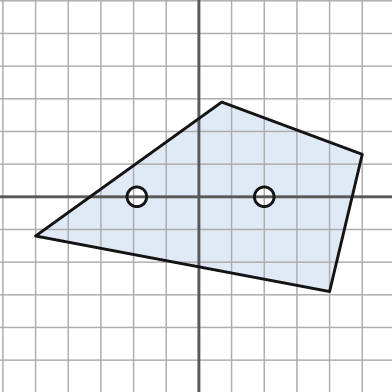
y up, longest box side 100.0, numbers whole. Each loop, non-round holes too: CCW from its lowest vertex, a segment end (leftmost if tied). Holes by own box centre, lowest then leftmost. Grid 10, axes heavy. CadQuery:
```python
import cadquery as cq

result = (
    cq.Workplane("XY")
    .moveTo(40.0, -29.0)
    .lineTo(50.0, 13.0)
    .lineTo(7.0, 29.0)
    .lineTo(-50.0, -12.0)
    .close()
    .moveTo(-19.0, 0.0)
    .circle(3.0)
    .moveTo(20.0, 0.0)
    .circle(3.0)
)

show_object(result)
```